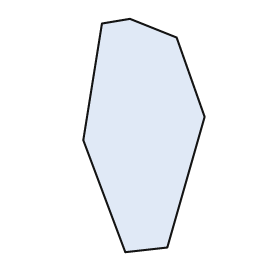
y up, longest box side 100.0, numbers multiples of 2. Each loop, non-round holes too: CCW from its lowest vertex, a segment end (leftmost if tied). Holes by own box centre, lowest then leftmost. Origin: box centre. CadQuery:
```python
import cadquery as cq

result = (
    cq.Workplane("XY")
    .moveTo(-8.0, -50.0)
    .lineTo(10.0, -48.0)
    .lineTo(26.0, 8.0)
    .lineTo(14.0, 42.0)
    .lineTo(-6.0, 50.0)
    .lineTo(-18.0, 48.0)
    .lineTo(-26.0, -2.0)
    .close()
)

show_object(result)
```